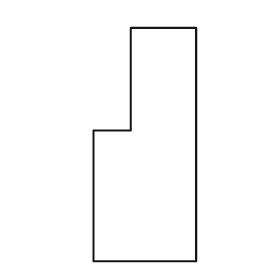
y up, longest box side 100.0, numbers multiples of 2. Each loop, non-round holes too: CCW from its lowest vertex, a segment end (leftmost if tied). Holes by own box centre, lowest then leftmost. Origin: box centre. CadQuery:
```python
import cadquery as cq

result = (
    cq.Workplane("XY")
    .moveTo(-22.0, -50.0)
    .lineTo(22.0, -50.0)
    .lineTo(22.0, 50.0)
    .lineTo(-6.0, 50.0)
    .lineTo(-6.0, 6.0)
    .lineTo(-22.0, 6.0)
    .close()
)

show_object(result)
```